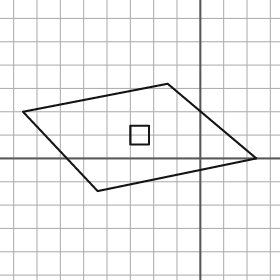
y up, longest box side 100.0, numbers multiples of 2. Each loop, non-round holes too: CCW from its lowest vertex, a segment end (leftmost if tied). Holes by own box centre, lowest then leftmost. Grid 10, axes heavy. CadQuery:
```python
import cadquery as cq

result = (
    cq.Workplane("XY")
    .moveTo(-44.0, -14.0)
    .lineTo(24.0, 0.0)
    .lineTo(-14.0, 32.0)
    .lineTo(-76.0, 20.0)
    .close()
    .moveTo(-30.0, 6.0)
    .lineTo(-22.0, 6.0)
    .lineTo(-22.0, 14.0)
    .lineTo(-30.0, 14.0)
    .close()
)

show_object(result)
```